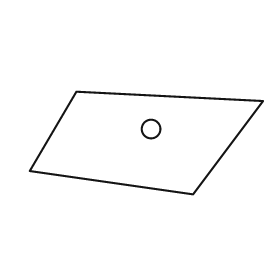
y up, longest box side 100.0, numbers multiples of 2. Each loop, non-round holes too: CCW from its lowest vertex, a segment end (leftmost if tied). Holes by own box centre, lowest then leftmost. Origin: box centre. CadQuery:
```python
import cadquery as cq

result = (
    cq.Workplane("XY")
    .moveTo(20.0, -22.0)
    .lineTo(50.0, 18.0)
    .lineTo(-30.0, 22.0)
    .lineTo(-50.0, -12.0)
    .close()
    .moveTo(2.0, 6.0)
    .circle(4.0)
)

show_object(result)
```